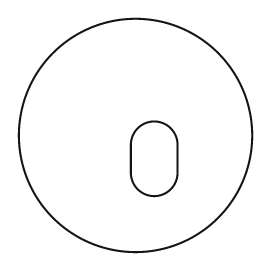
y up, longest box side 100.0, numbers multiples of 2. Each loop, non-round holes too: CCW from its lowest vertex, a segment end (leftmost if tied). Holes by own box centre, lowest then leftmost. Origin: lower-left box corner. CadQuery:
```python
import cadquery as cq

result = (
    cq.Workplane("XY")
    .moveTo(50.0, 50.0)
    .circle(50.0)
    .moveTo(48.0, 34.0)
    .threePointArc((58.0, 24.0), (68.0, 34.0))
    .lineTo(68.0, 46.0)
    .threePointArc((58.0, 56.0), (48.0, 46.0))
    .close()
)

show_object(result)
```